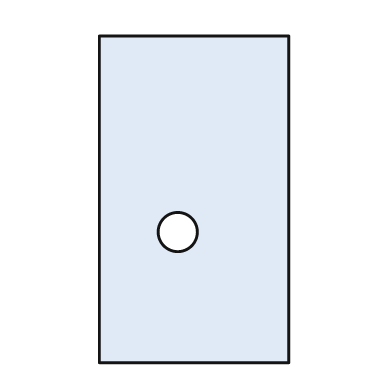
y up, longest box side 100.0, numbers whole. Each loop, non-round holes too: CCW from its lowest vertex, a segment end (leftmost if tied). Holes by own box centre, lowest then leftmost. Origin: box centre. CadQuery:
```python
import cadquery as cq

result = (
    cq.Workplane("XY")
    .moveTo(-29.0, -50.0)
    .lineTo(29.0, -50.0)
    .lineTo(29.0, 50.0)
    .lineTo(-29.0, 50.0)
    .close()
    .moveTo(-5.0, -10.0)
    .circle(6.0)
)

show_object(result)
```